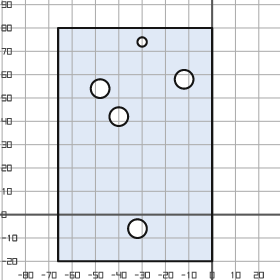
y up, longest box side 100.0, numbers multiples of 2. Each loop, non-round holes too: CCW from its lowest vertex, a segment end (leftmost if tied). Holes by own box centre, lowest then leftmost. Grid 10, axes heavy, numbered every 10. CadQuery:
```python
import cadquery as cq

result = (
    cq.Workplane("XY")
    .moveTo(-66.0, -20.0)
    .lineTo(0.0, -20.0)
    .lineTo(0.0, 80.0)
    .lineTo(-66.0, 80.0)
    .close()
    .moveTo(-32.0, -6.0)
    .circle(4.0)
    .moveTo(-40.0, 42.0)
    .circle(4.0)
    .moveTo(-48.0, 54.0)
    .circle(4.0)
    .moveTo(-12.0, 58.0)
    .circle(4.0)
    .moveTo(-30.0, 74.0)
    .circle(2.0)
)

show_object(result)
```